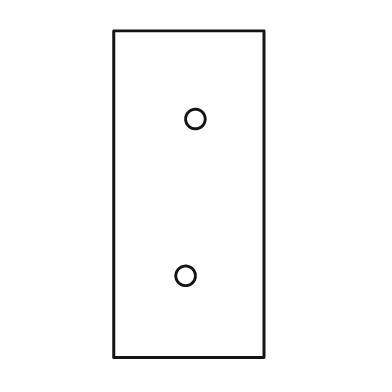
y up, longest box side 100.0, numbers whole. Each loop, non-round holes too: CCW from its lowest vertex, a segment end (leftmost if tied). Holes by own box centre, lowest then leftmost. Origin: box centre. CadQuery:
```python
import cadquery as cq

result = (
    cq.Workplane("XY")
    .moveTo(-23.0, -50.0)
    .lineTo(23.0, -50.0)
    .lineTo(23.0, 50.0)
    .lineTo(-23.0, 50.0)
    .close()
    .moveTo(-1.0, -25.0)
    .circle(3.0)
    .moveTo(2.0, 23.0)
    .circle(3.0)
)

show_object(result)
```